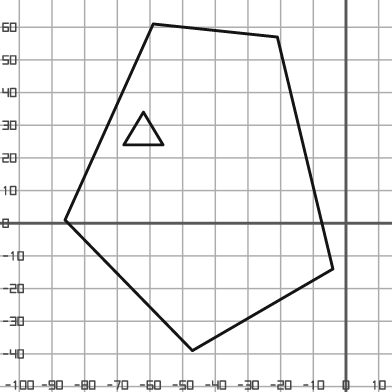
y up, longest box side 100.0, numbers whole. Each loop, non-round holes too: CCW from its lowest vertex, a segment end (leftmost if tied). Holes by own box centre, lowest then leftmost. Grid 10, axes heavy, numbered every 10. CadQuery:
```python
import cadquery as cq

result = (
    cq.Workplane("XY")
    .moveTo(-47.0, -39.0)
    .lineTo(-4.0, -14.0)
    .lineTo(-21.0, 57.0)
    .lineTo(-59.0, 61.0)
    .lineTo(-86.0, 1.0)
    .close()
    .moveTo(-68.0, 24.0)
    .lineTo(-56.0, 24.0)
    .lineTo(-62.0, 34.0)
    .close()
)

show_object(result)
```